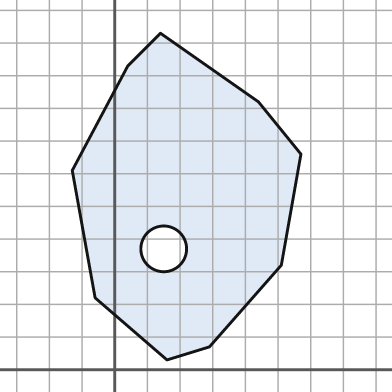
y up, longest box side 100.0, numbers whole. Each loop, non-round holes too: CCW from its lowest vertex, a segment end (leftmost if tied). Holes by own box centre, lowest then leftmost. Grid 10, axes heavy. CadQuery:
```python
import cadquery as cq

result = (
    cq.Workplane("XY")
    .moveTo(16.0, 3.0)
    .lineTo(29.0, 7.0)
    .lineTo(51.0, 32.0)
    .lineTo(57.0, 66.0)
    .lineTo(44.0, 82.0)
    .lineTo(14.0, 103.0)
    .lineTo(4.0, 93.0)
    .lineTo(-13.0, 61.0)
    .lineTo(-6.0, 22.0)
    .close()
    .moveTo(15.0, 37.0)
    .circle(7.0)
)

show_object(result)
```